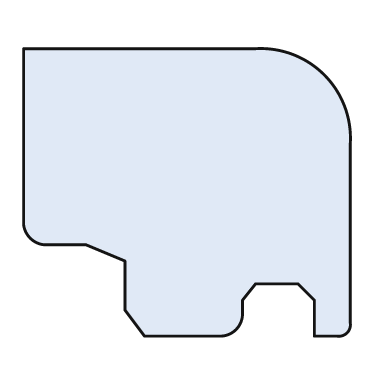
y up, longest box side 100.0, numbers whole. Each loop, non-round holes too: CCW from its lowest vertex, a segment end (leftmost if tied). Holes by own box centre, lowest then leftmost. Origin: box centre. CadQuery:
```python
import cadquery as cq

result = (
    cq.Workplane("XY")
    .moveTo(-13.0, -44.0)
    .lineTo(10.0, -44.0)
    .threePointArc((15.0, -42.0), (17.0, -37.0))
    .lineTo(17.0, -33.0)
    .lineTo(21.0, -28.0)
    .lineTo(34.0, -28.0)
    .lineTo(39.0, -33.0)
    .lineTo(39.0, -44.0)
    .lineTo(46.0, -44.0)
    .threePointArc((49.0, -43.0), (50.0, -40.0))
    .lineTo(50.0, 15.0)
    .threePointArc((42.0, 36.0), (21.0, 44.0))
    .lineTo(-50.0, 44.0)
    .lineTo(-50.0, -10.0)
    .threePointArc((-48.0, -14.0), (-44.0, -16.0))
    .lineTo(-31.0, -16.0)
    .lineTo(-19.0, -21.0)
    .lineTo(-19.0, -36.0)
    .close()
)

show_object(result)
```